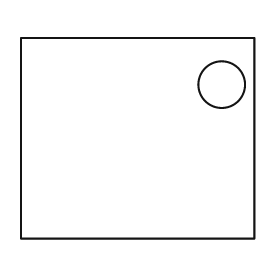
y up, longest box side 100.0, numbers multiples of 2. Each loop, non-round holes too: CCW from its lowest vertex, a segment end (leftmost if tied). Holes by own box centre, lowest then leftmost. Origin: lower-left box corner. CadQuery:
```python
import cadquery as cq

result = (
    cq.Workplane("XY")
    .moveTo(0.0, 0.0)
    .lineTo(100.0, 0.0)
    .lineTo(100.0, 86.0)
    .lineTo(0.0, 86.0)
    .close()
    .moveTo(86.0, 66.0)
    .circle(10.0)
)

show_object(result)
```